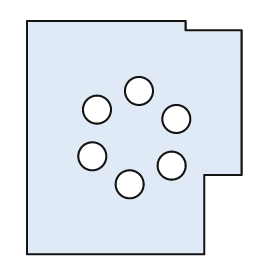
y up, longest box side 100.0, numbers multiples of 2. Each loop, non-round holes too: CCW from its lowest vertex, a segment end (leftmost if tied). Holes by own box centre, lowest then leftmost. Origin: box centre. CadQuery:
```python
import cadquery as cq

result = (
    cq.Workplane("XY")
    .moveTo(-46.0, -50.0)
    .lineTo(30.0, -50.0)
    .lineTo(30.0, -16.0)
    .lineTo(46.0, -16.0)
    .lineTo(46.0, 46.0)
    .lineTo(22.0, 46.0)
    .lineTo(22.0, 50.0)
    .lineTo(-46.0, 50.0)
    .close()
    .moveTo(-2.0, -20.0)
    .circle(6.0)
    .moveTo(16.0, -12.0)
    .circle(6.0)
    .moveTo(-18.0, -8.0)
    .circle(6.0)
    .moveTo(18.0, 8.0)
    .circle(6.0)
    .moveTo(-16.0, 12.0)
    .circle(6.0)
    .moveTo(2.0, 20.0)
    .circle(6.0)
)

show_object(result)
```